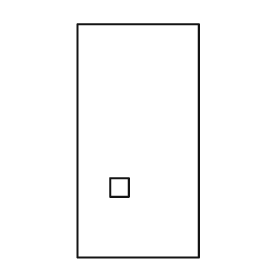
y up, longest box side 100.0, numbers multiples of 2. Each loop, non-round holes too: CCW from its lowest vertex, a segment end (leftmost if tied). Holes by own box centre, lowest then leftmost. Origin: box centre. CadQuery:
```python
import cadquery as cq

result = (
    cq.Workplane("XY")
    .moveTo(-26.0, -50.0)
    .lineTo(26.0, -50.0)
    .lineTo(26.0, 50.0)
    .lineTo(-26.0, 50.0)
    .close()
    .moveTo(-12.0, -24.0)
    .lineTo(-4.0, -24.0)
    .lineTo(-4.0, -16.0)
    .lineTo(-12.0, -16.0)
    .close()
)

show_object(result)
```